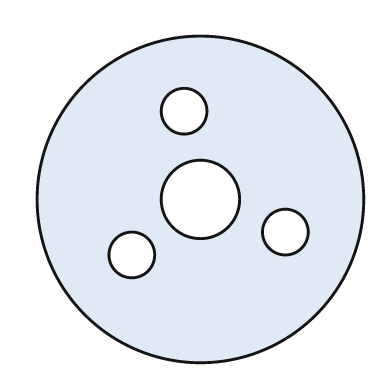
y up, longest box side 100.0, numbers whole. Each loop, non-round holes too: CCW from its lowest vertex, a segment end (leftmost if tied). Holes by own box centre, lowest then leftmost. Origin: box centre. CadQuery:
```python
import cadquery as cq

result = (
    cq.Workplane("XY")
    .moveTo(0.0, 0.0)
    .circle(50.0)
    .moveTo(-21.0, -17.0)
    .circle(7.0)
    .moveTo(26.0, -10.0)
    .circle(7.0)
    .moveTo(0.0, 0.0)
    .circle(12.0)
    .moveTo(-5.0, 27.0)
    .circle(7.0)
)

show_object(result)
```